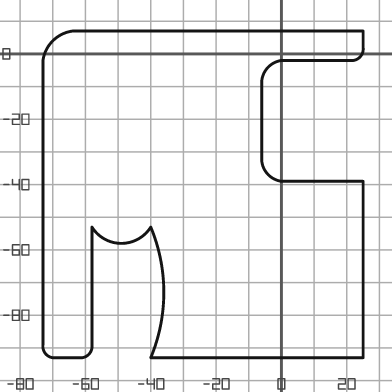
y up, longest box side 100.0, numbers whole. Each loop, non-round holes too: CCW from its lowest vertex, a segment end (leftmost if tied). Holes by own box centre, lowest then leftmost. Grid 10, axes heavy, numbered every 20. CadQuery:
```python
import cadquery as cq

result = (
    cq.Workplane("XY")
    .moveTo(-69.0, -93.0)
    .lineTo(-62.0, -93.0)
    .threePointArc((-59.0, -92.0), (-58.0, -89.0))
    .lineTo(-58.0, -53.0)
    .threePointArc((-49.0, -58.0), (-40.0, -53.0))
    .threePointArc((-36.0, -73.0), (-40.0, -93.0))
    .lineTo(25.0, -93.0)
    .lineTo(25.0, -39.0)
    .lineTo(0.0, -39.0)
    .threePointArc((-4.0, -37.0), (-6.0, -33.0))
    .lineTo(-6.0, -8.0)
    .threePointArc((-4.0, -4.0), (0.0, -2.0))
    .lineTo(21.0, -2.0)
    .threePointArc((24.0, -1.0), (25.0, 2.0))
    .lineTo(25.0, 7.0)
    .lineTo(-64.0, 7.0)
    .threePointArc((-70.0, 4.0), (-73.0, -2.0))
    .lineTo(-73.0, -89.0)
    .threePointArc((-72.0, -92.0), (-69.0, -93.0))
    .close()
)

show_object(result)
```